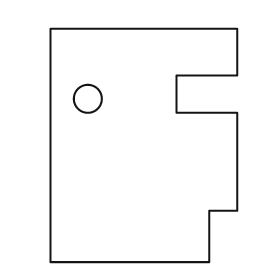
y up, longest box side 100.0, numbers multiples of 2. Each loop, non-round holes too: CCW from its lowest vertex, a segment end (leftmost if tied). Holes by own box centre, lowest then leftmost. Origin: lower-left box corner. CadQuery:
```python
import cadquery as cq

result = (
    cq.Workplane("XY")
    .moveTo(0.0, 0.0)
    .lineTo(68.0, 0.0)
    .lineTo(68.0, 22.0)
    .lineTo(80.0, 22.0)
    .lineTo(80.0, 64.0)
    .lineTo(54.0, 64.0)
    .lineTo(54.0, 80.0)
    .lineTo(80.0, 80.0)
    .lineTo(80.0, 100.0)
    .lineTo(0.0, 100.0)
    .close()
    .moveTo(16.0, 70.0)
    .circle(6.0)
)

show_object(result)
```